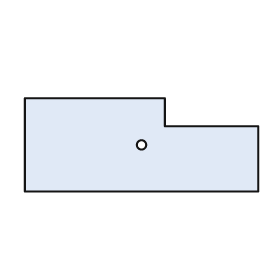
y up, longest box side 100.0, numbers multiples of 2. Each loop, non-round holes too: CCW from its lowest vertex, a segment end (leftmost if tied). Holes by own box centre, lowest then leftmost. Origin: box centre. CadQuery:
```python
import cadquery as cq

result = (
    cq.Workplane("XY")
    .moveTo(-50.0, -20.0)
    .lineTo(50.0, -20.0)
    .lineTo(50.0, 8.0)
    .lineTo(10.0, 8.0)
    .lineTo(10.0, 20.0)
    .lineTo(-50.0, 20.0)
    .close()
    .moveTo(0.0, 0.0)
    .circle(2.0)
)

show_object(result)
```